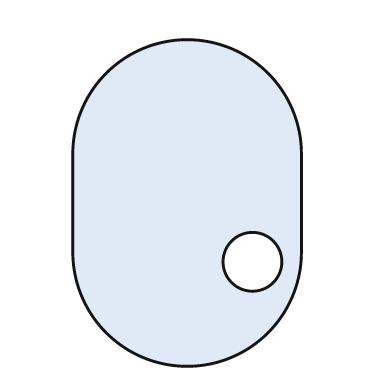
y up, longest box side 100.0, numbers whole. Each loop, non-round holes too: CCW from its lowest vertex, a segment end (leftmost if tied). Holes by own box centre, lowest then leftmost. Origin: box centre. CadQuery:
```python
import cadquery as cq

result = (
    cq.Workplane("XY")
    .moveTo(-35.0, -15.0)
    .threePointArc((0.0, -50.0), (35.0, -15.0))
    .lineTo(35.0, 15.0)
    .threePointArc((0.0, 50.0), (-35.0, 15.0))
    .close()
    .moveTo(20.0, -18.0)
    .circle(9.0)
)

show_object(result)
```